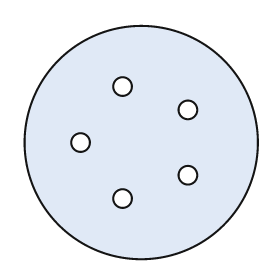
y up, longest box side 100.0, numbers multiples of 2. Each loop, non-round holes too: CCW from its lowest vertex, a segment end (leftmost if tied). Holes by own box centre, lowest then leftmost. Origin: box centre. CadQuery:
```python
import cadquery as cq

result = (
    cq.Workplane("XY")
    .moveTo(0.0, 0.0)
    .circle(50.0)
    .moveTo(-8.0, -24.0)
    .circle(4.0)
    .moveTo(20.0, -14.0)
    .circle(4.0)
    .moveTo(-26.0, 0.0)
    .circle(4.0)
    .moveTo(20.0, 14.0)
    .circle(4.0)
    .moveTo(-8.0, 24.0)
    .circle(4.0)
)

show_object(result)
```